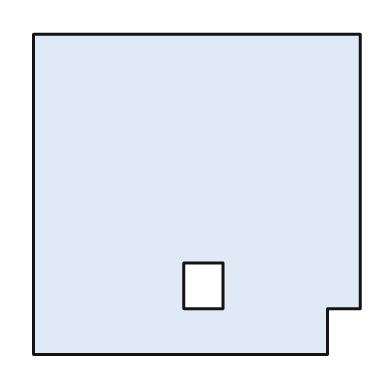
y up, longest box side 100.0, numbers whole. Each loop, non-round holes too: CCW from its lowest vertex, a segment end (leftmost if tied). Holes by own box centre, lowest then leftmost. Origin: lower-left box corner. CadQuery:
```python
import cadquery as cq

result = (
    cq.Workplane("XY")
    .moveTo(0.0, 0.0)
    .lineTo(90.0, 0.0)
    .lineTo(90.0, 14.0)
    .lineTo(100.0, 14.0)
    .lineTo(100.0, 98.0)
    .lineTo(0.0, 98.0)
    .close()
    .moveTo(46.0, 14.0)
    .lineTo(58.0, 14.0)
    .lineTo(58.0, 28.0)
    .lineTo(46.0, 28.0)
    .close()
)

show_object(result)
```